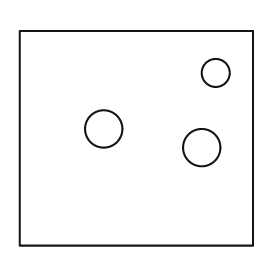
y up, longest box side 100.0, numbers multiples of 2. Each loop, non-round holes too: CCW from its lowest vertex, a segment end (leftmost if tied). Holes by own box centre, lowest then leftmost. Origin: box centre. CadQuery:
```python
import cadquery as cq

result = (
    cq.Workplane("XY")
    .moveTo(-50.0, -46.0)
    .lineTo(50.0, -46.0)
    .lineTo(50.0, 46.0)
    .lineTo(-50.0, 46.0)
    .close()
    .moveTo(28.0, -4.0)
    .circle(8.0)
    .moveTo(-14.0, 4.0)
    .circle(8.0)
    .moveTo(34.0, 28.0)
    .circle(6.0)
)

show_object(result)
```